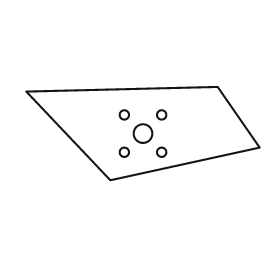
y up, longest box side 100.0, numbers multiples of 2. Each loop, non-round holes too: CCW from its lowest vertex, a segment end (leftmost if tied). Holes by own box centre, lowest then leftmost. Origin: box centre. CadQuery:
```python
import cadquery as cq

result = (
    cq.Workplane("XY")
    .moveTo(-14.0, -20.0)
    .lineTo(50.0, -6.0)
    .lineTo(32.0, 20.0)
    .lineTo(-50.0, 18.0)
    .close()
    .moveTo(-8.0, -8.0)
    .circle(2.0)
    .moveTo(8.0, -8.0)
    .circle(2.0)
    .moveTo(0.0, 0.0)
    .circle(4.0)
    .moveTo(-8.0, 8.0)
    .circle(2.0)
    .moveTo(8.0, 8.0)
    .circle(2.0)
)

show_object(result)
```